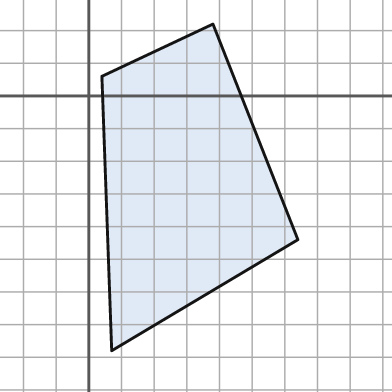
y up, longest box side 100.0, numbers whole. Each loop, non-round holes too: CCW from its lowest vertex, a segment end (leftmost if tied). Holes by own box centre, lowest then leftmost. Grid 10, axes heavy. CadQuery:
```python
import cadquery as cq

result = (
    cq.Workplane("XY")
    .moveTo(7.0, -78.0)
    .lineTo(64.0, -44.0)
    .lineTo(38.0, 22.0)
    .lineTo(4.0, 6.0)
    .close()
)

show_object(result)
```